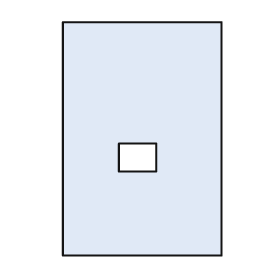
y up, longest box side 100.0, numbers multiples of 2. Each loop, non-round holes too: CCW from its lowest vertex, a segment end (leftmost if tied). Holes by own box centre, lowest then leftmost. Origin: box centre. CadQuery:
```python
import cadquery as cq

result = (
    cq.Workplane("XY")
    .moveTo(-34.0, -50.0)
    .lineTo(34.0, -50.0)
    .lineTo(34.0, 50.0)
    .lineTo(-34.0, 50.0)
    .close()
    .moveTo(-10.0, -14.0)
    .lineTo(6.0, -14.0)
    .lineTo(6.0, -2.0)
    .lineTo(-10.0, -2.0)
    .close()
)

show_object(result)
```